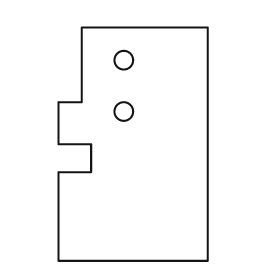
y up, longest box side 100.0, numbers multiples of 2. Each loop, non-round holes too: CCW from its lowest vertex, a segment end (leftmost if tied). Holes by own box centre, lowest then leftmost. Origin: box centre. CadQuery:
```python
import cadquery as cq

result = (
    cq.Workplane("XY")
    .moveTo(-32.0, -50.0)
    .lineTo(32.0, -50.0)
    .lineTo(32.0, 50.0)
    .lineTo(-22.0, 50.0)
    .lineTo(-22.0, 18.0)
    .lineTo(-32.0, 18.0)
    .lineTo(-32.0, 0.0)
    .lineTo(-18.0, 0.0)
    .lineTo(-18.0, -12.0)
    .lineTo(-32.0, -12.0)
    .close()
    .moveTo(-4.0, 14.0)
    .circle(4.0)
    .moveTo(-4.0, 36.0)
    .circle(4.0)
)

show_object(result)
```